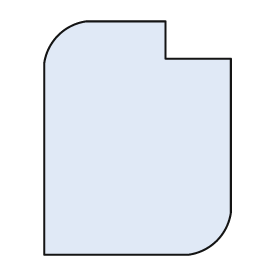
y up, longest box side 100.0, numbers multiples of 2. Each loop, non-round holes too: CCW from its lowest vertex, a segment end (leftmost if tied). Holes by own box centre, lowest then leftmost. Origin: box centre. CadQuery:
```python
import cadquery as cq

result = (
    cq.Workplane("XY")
    .moveTo(-40.0, -50.0)
    .lineTo(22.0, -50.0)
    .threePointArc((34.0, -44.0), (40.0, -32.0))
    .lineTo(40.0, 34.0)
    .lineTo(12.0, 34.0)
    .lineTo(12.0, 50.0)
    .lineTo(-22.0, 50.0)
    .threePointArc((-34.0, 44.0), (-40.0, 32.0))
    .close()
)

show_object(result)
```